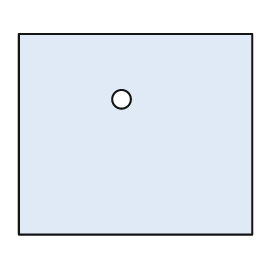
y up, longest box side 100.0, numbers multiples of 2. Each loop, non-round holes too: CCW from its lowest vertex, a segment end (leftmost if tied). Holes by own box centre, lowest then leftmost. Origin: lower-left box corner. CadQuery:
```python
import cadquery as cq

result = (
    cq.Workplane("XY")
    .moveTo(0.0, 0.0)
    .lineTo(100.0, 0.0)
    .lineTo(100.0, 86.0)
    .lineTo(0.0, 86.0)
    .close()
    .moveTo(44.0, 58.0)
    .circle(4.0)
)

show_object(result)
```